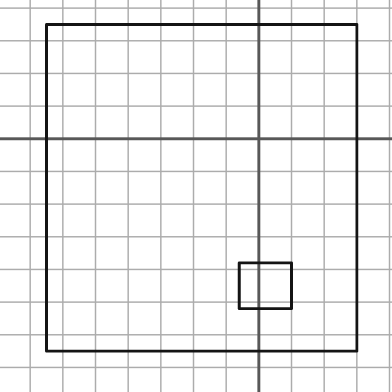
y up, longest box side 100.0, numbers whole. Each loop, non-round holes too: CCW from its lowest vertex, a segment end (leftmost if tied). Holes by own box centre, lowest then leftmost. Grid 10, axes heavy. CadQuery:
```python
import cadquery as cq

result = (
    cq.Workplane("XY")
    .moveTo(-65.0, -65.0)
    .lineTo(30.0, -65.0)
    .lineTo(30.0, 35.0)
    .lineTo(-65.0, 35.0)
    .close()
    .moveTo(-6.0, -52.0)
    .lineTo(10.0, -52.0)
    .lineTo(10.0, -38.0)
    .lineTo(-6.0, -38.0)
    .close()
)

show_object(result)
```